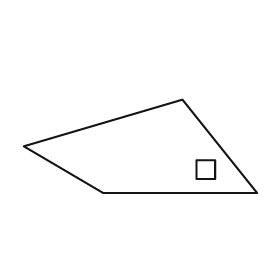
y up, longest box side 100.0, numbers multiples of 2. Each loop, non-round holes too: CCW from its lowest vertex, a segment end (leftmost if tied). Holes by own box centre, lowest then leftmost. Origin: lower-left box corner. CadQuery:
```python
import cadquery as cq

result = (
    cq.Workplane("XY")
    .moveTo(34.0, 0.0)
    .lineTo(100.0, 0.0)
    .lineTo(68.0, 40.0)
    .lineTo(0.0, 20.0)
    .close()
    .moveTo(74.0, 6.0)
    .lineTo(82.0, 6.0)
    .lineTo(82.0, 14.0)
    .lineTo(74.0, 14.0)
    .close()
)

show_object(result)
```